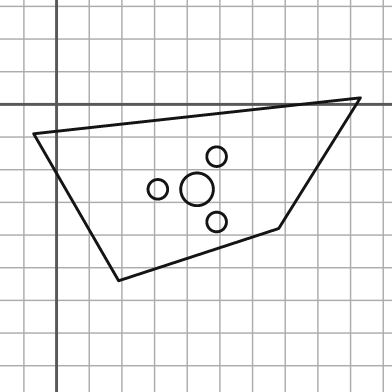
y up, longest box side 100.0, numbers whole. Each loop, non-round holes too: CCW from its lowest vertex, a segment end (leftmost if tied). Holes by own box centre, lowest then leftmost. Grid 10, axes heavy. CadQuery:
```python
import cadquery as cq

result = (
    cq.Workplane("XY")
    .moveTo(19.0, -54.0)
    .lineTo(68.0, -38.0)
    .lineTo(93.0, 2.0)
    .lineTo(-7.0, -9.0)
    .close()
    .moveTo(49.0, -36.0)
    .circle(3.0)
    .moveTo(31.0, -26.0)
    .circle(3.0)
    .moveTo(43.0, -26.0)
    .circle(5.0)
    .moveTo(49.0, -16.0)
    .circle(3.0)
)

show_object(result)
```